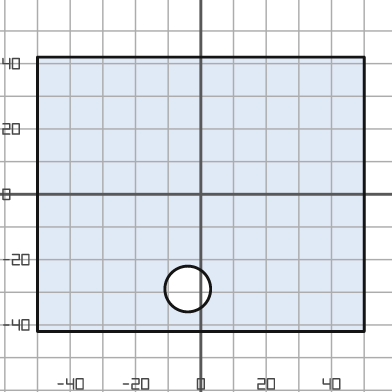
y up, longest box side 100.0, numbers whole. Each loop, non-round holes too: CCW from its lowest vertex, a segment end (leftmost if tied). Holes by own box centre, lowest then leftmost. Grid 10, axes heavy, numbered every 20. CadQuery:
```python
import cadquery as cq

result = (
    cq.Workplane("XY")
    .moveTo(-50.0, -42.0)
    .lineTo(50.0, -42.0)
    .lineTo(50.0, 42.0)
    .lineTo(-50.0, 42.0)
    .close()
    .moveTo(-4.0, -29.0)
    .circle(7.0)
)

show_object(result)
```